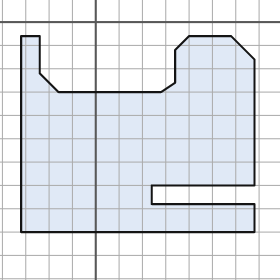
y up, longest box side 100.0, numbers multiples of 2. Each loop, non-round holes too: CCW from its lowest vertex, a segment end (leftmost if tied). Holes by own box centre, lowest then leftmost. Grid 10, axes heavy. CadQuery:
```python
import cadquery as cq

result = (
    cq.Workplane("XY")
    .moveTo(-32.0, -90.0)
    .lineTo(68.0, -90.0)
    .lineTo(68.0, -78.0)
    .lineTo(24.0, -78.0)
    .lineTo(24.0, -70.0)
    .lineTo(68.0, -70.0)
    .lineTo(68.0, -16.0)
    .lineTo(58.0, -6.0)
    .lineTo(40.0, -6.0)
    .lineTo(34.0, -12.0)
    .lineTo(34.0, -26.0)
    .lineTo(28.0, -30.0)
    .lineTo(-16.0, -30.0)
    .lineTo(-24.0, -22.0)
    .lineTo(-24.0, -6.0)
    .lineTo(-32.0, -6.0)
    .close()
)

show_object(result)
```